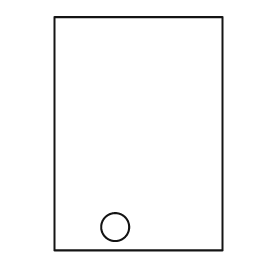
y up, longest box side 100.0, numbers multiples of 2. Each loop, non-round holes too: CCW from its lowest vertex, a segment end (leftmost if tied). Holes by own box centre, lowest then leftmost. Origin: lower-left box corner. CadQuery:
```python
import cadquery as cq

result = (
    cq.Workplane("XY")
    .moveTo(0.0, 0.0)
    .lineTo(72.0, 0.0)
    .lineTo(72.0, 100.0)
    .lineTo(0.0, 100.0)
    .close()
    .moveTo(26.0, 10.0)
    .circle(6.0)
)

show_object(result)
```